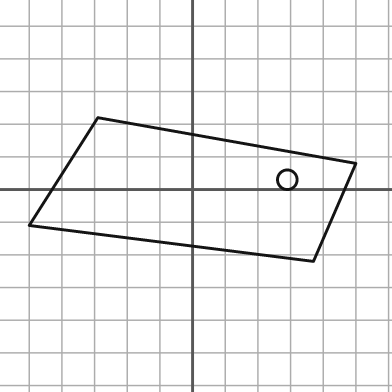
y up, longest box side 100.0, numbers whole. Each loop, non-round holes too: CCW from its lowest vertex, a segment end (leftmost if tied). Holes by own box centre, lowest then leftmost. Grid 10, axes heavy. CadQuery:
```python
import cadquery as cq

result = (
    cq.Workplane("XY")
    .moveTo(37.0, -22.0)
    .lineTo(50.0, 8.0)
    .lineTo(-29.0, 22.0)
    .lineTo(-50.0, -11.0)
    .close()
    .moveTo(29.0, 3.0)
    .circle(3.0)
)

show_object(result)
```